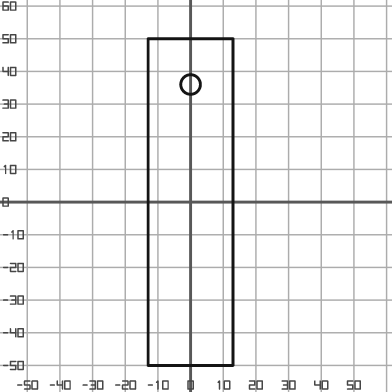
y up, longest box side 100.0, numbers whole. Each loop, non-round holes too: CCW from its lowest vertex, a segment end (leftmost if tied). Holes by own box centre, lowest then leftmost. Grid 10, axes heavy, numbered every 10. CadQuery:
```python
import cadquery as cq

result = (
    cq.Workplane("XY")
    .moveTo(-13.0, -50.0)
    .lineTo(13.0, -50.0)
    .lineTo(13.0, 50.0)
    .lineTo(-13.0, 50.0)
    .close()
    .moveTo(0.0, 36.0)
    .circle(3.0)
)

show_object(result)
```